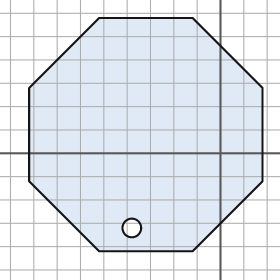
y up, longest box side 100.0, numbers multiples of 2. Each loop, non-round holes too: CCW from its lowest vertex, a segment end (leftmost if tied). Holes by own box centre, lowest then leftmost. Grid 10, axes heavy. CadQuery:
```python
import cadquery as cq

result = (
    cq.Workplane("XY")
    .moveTo(-52.0, -42.0)
    .lineTo(-12.0, -42.0)
    .lineTo(18.0, -12.0)
    .lineTo(18.0, 28.0)
    .lineTo(-12.0, 58.0)
    .lineTo(-52.0, 58.0)
    .lineTo(-82.0, 28.0)
    .lineTo(-82.0, -12.0)
    .close()
    .moveTo(-38.0, -32.0)
    .circle(4.0)
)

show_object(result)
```